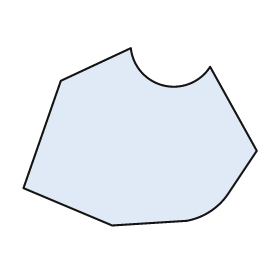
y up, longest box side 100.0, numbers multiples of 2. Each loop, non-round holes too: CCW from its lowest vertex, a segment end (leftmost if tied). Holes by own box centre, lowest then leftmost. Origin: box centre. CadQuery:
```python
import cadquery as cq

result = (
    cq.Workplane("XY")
    .moveTo(-12.0, -38.0)
    .lineTo(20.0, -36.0)
    .threePointArc((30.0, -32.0), (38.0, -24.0))
    .lineTo(50.0, -6.0)
    .lineTo(30.0, 30.0)
    .threePointArc((10.0, 22.0), (-4.0, 38.0))
    .lineTo(-34.0, 24.0)
    .lineTo(-50.0, -22.0)
    .close()
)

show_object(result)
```